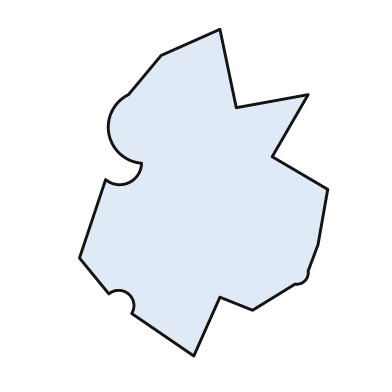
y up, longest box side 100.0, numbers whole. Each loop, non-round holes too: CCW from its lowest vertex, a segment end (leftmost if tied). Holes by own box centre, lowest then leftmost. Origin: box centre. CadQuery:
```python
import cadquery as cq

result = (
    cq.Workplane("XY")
    .moveTo(-3.0, -50.0)
    .lineTo(5.0, -32.0)
    .lineTo(15.0, -36.0)
    .lineTo(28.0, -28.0)
    .threePointArc((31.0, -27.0), (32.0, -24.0))
    .lineTo(35.0, -16.0)
    .lineTo(38.0, 1.0)
    .lineTo(21.0, 11.0)
    .lineTo(32.0, 30.0)
    .lineTo(10.0, 26.0)
    .lineTo(5.0, 50.0)
    .lineTo(-13.0, 42.0)
    .lineTo(-23.0, 30.0)
    .threePointArc((-29.0, 18.0), (-19.0, 9.0))
    .threePointArc((-23.0, 3.0), (-30.0, 4.0))
    .lineTo(-38.0, -20.0)
    .lineTo(-29.0, -31.0)
    .threePointArc((-23.0, -31.0), (-22.0, -37.0))
    .close()
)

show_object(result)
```